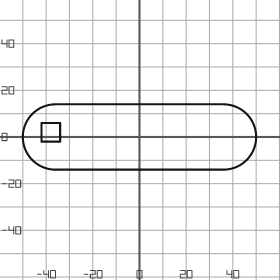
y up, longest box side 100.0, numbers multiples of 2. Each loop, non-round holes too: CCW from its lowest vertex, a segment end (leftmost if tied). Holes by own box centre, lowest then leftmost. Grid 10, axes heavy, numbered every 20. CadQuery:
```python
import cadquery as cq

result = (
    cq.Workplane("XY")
    .moveTo(-36.0, -14.0)
    .lineTo(36.0, -14.0)
    .threePointArc((50.0, 0.0), (36.0, 14.0))
    .lineTo(-36.0, 14.0)
    .threePointArc((-50.0, 0.0), (-36.0, -14.0))
    .close()
    .moveTo(-42.0, -2.0)
    .lineTo(-34.0, -2.0)
    .lineTo(-34.0, 6.0)
    .lineTo(-42.0, 6.0)
    .close()
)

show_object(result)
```